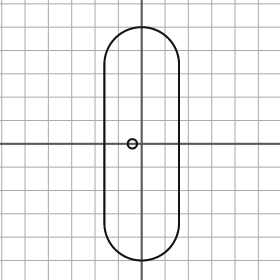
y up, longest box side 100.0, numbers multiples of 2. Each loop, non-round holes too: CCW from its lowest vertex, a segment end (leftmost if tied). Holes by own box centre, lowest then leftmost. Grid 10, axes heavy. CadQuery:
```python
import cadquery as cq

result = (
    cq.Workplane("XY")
    .moveTo(-16.0, -34.0)
    .threePointArc((0.0, -50.0), (16.0, -34.0))
    .lineTo(16.0, 34.0)
    .threePointArc((0.0, 50.0), (-16.0, 34.0))
    .close()
    .moveTo(-4.0, 0.0)
    .circle(2.0)
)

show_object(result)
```